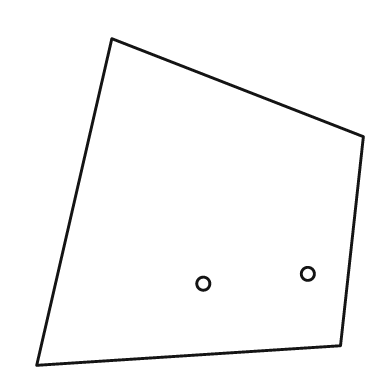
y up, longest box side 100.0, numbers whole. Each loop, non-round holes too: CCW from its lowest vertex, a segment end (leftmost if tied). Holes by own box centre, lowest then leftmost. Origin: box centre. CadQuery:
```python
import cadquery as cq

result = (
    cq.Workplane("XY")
    .moveTo(-50.0, -50.0)
    .lineTo(43.0, -44.0)
    .lineTo(50.0, 20.0)
    .lineTo(-27.0, 50.0)
    .close()
    .moveTo(1.0, -25.0)
    .circle(2.0)
    .moveTo(33.0, -22.0)
    .circle(2.0)
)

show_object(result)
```